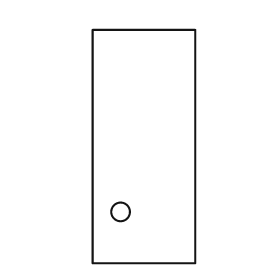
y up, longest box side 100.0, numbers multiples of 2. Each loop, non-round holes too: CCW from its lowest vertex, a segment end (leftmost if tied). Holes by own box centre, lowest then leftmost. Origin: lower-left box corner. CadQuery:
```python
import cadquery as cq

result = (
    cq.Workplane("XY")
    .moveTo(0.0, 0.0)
    .lineTo(44.0, 0.0)
    .lineTo(44.0, 100.0)
    .lineTo(0.0, 100.0)
    .close()
    .moveTo(12.0, 22.0)
    .circle(4.0)
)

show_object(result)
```